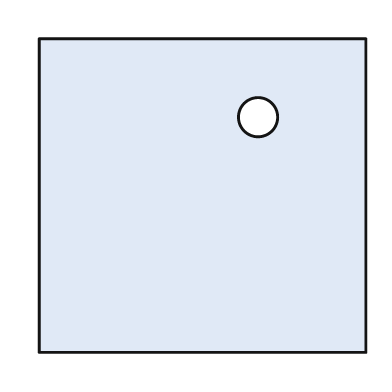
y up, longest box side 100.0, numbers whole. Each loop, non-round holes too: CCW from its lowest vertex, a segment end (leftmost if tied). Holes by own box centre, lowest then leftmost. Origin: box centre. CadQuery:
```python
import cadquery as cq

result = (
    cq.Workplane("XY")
    .moveTo(-50.0, -48.0)
    .lineTo(50.0, -48.0)
    .lineTo(50.0, 48.0)
    .lineTo(-50.0, 48.0)
    .close()
    .moveTo(17.0, 24.0)
    .circle(6.0)
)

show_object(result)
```